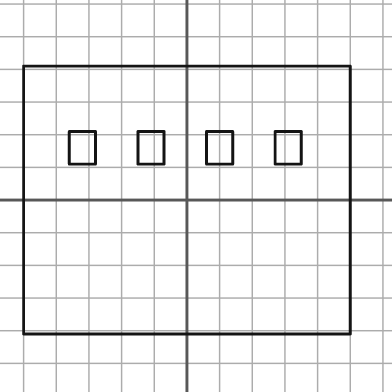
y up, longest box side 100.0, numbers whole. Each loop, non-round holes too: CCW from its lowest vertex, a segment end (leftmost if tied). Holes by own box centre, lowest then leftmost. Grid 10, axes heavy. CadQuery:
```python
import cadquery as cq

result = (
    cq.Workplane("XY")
    .moveTo(-50.0, -41.0)
    .lineTo(50.0, -41.0)
    .lineTo(50.0, 41.0)
    .lineTo(-50.0, 41.0)
    .close()
    .moveTo(-36.0, 11.0)
    .lineTo(-28.0, 11.0)
    .lineTo(-28.0, 21.0)
    .lineTo(-36.0, 21.0)
    .close()
    .moveTo(-15.0, 11.0)
    .lineTo(-7.0, 11.0)
    .lineTo(-7.0, 21.0)
    .lineTo(-15.0, 21.0)
    .close()
    .moveTo(6.0, 11.0)
    .lineTo(14.0, 11.0)
    .lineTo(14.0, 21.0)
    .lineTo(6.0, 21.0)
    .close()
    .moveTo(27.0, 11.0)
    .lineTo(35.0, 11.0)
    .lineTo(35.0, 21.0)
    .lineTo(27.0, 21.0)
    .close()
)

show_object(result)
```